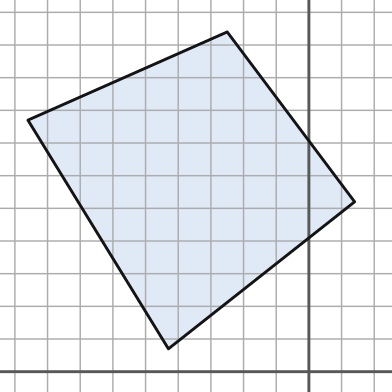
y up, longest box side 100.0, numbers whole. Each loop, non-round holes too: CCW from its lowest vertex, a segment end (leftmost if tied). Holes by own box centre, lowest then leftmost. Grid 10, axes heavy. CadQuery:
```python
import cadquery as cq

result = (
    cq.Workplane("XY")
    .moveTo(-43.0, 7.0)
    .lineTo(14.0, 52.0)
    .lineTo(-25.0, 104.0)
    .lineTo(-86.0, 77.0)
    .close()
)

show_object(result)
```